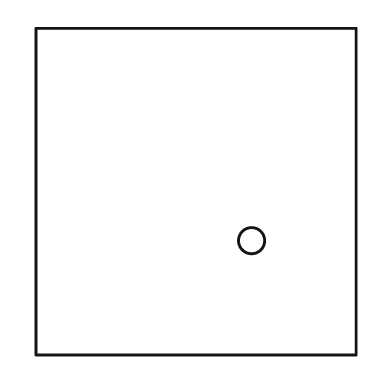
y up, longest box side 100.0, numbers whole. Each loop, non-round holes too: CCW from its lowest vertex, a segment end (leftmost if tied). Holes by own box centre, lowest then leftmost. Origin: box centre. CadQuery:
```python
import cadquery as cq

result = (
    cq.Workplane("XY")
    .moveTo(-49.0, -50.0)
    .lineTo(49.0, -50.0)
    .lineTo(49.0, 50.0)
    .lineTo(-49.0, 50.0)
    .close()
    .moveTo(17.0, -15.0)
    .circle(4.0)
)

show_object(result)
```